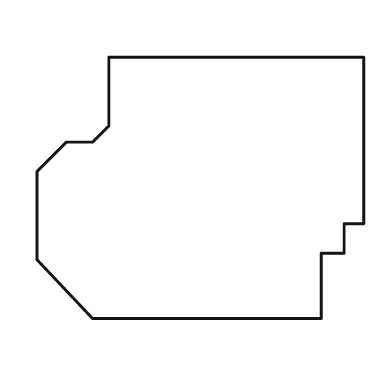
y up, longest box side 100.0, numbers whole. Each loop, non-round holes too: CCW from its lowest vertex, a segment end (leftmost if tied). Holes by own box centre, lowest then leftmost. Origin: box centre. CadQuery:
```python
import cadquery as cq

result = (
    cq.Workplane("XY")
    .moveTo(-33.0, -40.0)
    .lineTo(37.0, -40.0)
    .lineTo(37.0, -20.0)
    .lineTo(44.0, -20.0)
    .lineTo(44.0, -11.0)
    .lineTo(50.0, -11.0)
    .lineTo(50.0, 40.0)
    .lineTo(-28.0, 40.0)
    .lineTo(-28.0, 19.0)
    .lineTo(-33.0, 14.0)
    .lineTo(-41.0, 14.0)
    .lineTo(-50.0, 5.0)
    .lineTo(-50.0, -22.0)
    .close()
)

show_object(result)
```